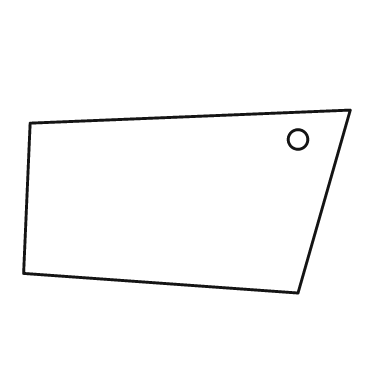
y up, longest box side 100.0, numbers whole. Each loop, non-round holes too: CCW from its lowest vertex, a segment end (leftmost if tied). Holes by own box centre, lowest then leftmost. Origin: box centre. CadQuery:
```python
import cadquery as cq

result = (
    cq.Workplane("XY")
    .moveTo(34.0, -28.0)
    .lineTo(50.0, 28.0)
    .lineTo(-48.0, 24.0)
    .lineTo(-50.0, -22.0)
    .close()
    .moveTo(34.0, 19.0)
    .circle(3.0)
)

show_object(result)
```